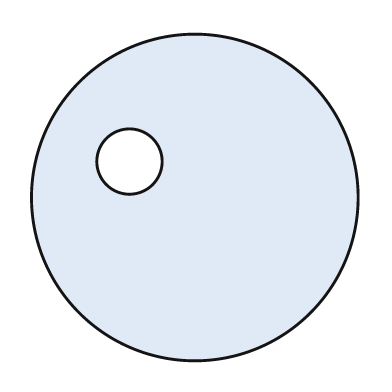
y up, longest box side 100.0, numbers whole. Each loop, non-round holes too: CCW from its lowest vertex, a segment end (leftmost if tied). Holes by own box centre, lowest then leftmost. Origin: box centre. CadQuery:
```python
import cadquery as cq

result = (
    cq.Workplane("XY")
    .moveTo(0.0, 0.0)
    .circle(50.0)
    .moveTo(-20.0, 11.0)
    .circle(10.0)
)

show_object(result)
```